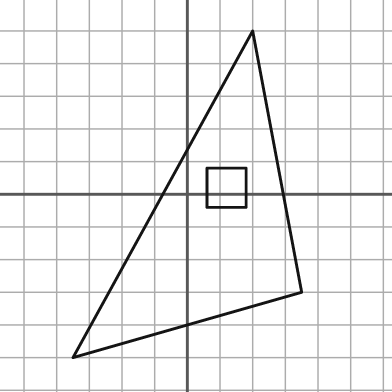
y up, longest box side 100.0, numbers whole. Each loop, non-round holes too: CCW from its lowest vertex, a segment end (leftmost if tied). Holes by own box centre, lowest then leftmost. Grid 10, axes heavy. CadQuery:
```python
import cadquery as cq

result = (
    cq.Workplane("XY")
    .moveTo(-35.0, -50.0)
    .lineTo(35.0, -30.0)
    .lineTo(20.0, 50.0)
    .close()
    .moveTo(6.0, -4.0)
    .lineTo(18.0, -4.0)
    .lineTo(18.0, 8.0)
    .lineTo(6.0, 8.0)
    .close()
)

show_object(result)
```